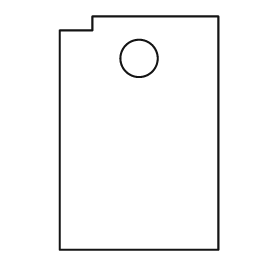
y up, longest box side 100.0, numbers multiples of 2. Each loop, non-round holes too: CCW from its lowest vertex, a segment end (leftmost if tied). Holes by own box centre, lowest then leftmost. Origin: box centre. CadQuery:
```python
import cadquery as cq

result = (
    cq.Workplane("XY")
    .moveTo(-34.0, -50.0)
    .lineTo(34.0, -50.0)
    .lineTo(34.0, 50.0)
    .lineTo(-20.0, 50.0)
    .lineTo(-20.0, 44.0)
    .lineTo(-34.0, 44.0)
    .close()
    .moveTo(0.0, 32.0)
    .circle(8.0)
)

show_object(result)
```